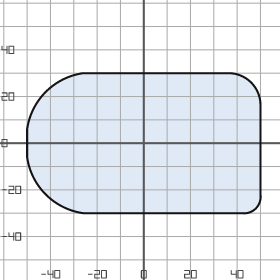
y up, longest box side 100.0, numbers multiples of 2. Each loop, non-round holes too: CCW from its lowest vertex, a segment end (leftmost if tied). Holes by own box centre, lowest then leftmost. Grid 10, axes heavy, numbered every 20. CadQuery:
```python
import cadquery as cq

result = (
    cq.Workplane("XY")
    .moveTo(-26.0, -30.0)
    .lineTo(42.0, -30.0)
    .threePointArc((48.0, -28.0), (50.0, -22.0))
    .lineTo(50.0, 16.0)
    .threePointArc((46.0, 26.0), (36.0, 30.0))
    .lineTo(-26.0, 30.0)
    .threePointArc((-42.0, 22.0), (-50.0, 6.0))
    .lineTo(-50.0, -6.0)
    .threePointArc((-42.0, -22.0), (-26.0, -30.0))
    .close()
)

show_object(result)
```